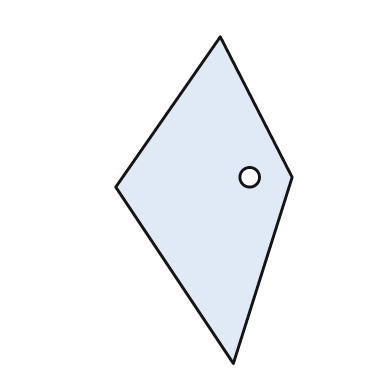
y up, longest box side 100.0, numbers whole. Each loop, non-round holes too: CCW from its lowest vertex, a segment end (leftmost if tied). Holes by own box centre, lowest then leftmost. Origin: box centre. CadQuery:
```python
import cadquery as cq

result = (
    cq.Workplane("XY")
    .moveTo(9.0, -50.0)
    .lineTo(27.0, 7.0)
    .lineTo(5.0, 50.0)
    .lineTo(-27.0, 4.0)
    .close()
    .moveTo(14.0, 7.0)
    .circle(3.0)
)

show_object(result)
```